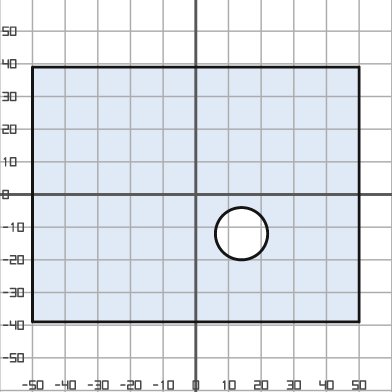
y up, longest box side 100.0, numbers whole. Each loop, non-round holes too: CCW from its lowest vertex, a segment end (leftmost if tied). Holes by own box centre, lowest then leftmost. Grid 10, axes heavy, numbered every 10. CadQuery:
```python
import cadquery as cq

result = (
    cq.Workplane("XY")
    .moveTo(-50.0, -39.0)
    .lineTo(50.0, -39.0)
    .lineTo(50.0, 39.0)
    .lineTo(-50.0, 39.0)
    .close()
    .moveTo(14.0, -12.0)
    .circle(8.0)
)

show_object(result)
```